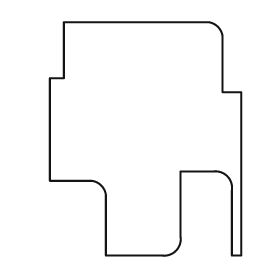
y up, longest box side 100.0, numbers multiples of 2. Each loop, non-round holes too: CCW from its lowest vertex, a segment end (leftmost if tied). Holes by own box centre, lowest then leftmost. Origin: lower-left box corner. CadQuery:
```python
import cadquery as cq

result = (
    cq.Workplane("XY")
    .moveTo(24.0, 0.0)
    .lineTo(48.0, 0.0)
    .threePointArc((54.0, 2.0), (56.0, 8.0))
    .lineTo(56.0, 36.0)
    .lineTo(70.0, 36.0)
    .threePointArc((76.0, 34.0), (78.0, 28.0))
    .lineTo(78.0, 0.0)
    .lineTo(82.0, 0.0)
    .lineTo(82.0, 70.0)
    .lineTo(74.0, 70.0)
    .lineTo(74.0, 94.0)
    .threePointArc((72.0, 98.0), (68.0, 100.0))
    .lineTo(6.0, 100.0)
    .lineTo(6.0, 76.0)
    .lineTo(0.0, 76.0)
    .lineTo(0.0, 32.0)
    .lineTo(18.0, 32.0)
    .threePointArc((22.0, 30.0), (24.0, 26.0))
    .close()
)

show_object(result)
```